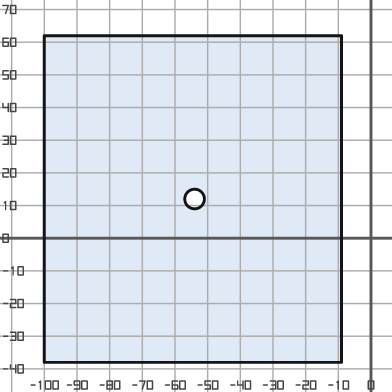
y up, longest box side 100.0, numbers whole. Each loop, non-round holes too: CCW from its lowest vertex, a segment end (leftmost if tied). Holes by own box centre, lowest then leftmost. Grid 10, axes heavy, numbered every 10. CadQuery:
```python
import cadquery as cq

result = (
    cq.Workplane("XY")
    .moveTo(-100.0, -38.0)
    .lineTo(-9.0, -38.0)
    .lineTo(-9.0, 62.0)
    .lineTo(-100.0, 62.0)
    .close()
    .moveTo(-54.0, 12.0)
    .circle(3.0)
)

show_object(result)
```